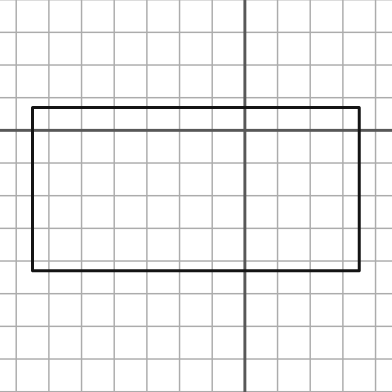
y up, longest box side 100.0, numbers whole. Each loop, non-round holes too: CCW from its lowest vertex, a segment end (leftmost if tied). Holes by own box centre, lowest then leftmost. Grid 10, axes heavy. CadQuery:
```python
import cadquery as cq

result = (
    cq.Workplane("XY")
    .moveTo(-65.0, -43.0)
    .lineTo(35.0, -43.0)
    .lineTo(35.0, 7.0)
    .lineTo(-65.0, 7.0)
    .close()
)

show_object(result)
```